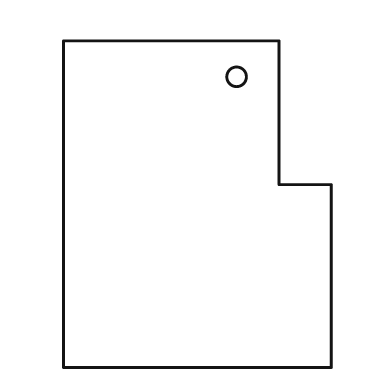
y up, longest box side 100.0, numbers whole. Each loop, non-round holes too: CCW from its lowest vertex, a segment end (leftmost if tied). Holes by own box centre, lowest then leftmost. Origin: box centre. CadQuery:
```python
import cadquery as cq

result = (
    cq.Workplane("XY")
    .moveTo(-41.0, -50.0)
    .lineTo(41.0, -50.0)
    .lineTo(41.0, 6.0)
    .lineTo(25.0, 6.0)
    .lineTo(25.0, 50.0)
    .lineTo(-41.0, 50.0)
    .close()
    .moveTo(12.0, 39.0)
    .circle(3.0)
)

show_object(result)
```